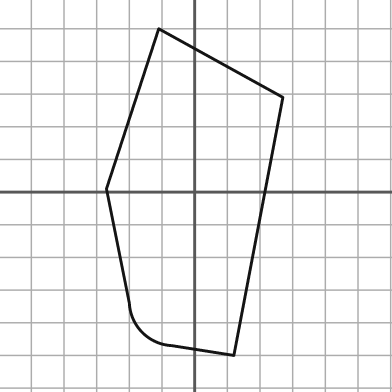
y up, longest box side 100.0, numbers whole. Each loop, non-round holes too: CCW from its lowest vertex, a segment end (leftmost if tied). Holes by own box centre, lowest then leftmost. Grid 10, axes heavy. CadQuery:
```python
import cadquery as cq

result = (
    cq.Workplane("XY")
    .moveTo(12.0, -50.0)
    .lineTo(27.0, 29.0)
    .lineTo(-11.0, 50.0)
    .lineTo(-27.0, 1.0)
    .lineTo(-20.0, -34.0)
    .threePointArc((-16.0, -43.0), (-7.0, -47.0))
    .close()
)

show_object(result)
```